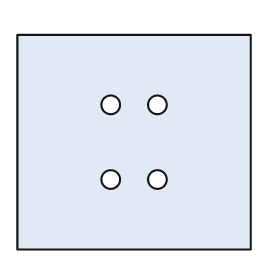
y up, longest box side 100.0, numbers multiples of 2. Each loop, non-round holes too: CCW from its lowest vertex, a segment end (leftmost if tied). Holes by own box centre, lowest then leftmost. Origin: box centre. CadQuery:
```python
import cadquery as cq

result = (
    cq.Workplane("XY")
    .moveTo(-50.0, -46.0)
    .lineTo(50.0, -46.0)
    .lineTo(50.0, 46.0)
    .lineTo(-50.0, 46.0)
    .close()
    .moveTo(-10.0, -16.0)
    .circle(4.0)
    .moveTo(10.0, -16.0)
    .circle(4.0)
    .moveTo(-10.0, 16.0)
    .circle(4.0)
    .moveTo(10.0, 16.0)
    .circle(4.0)
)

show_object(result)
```